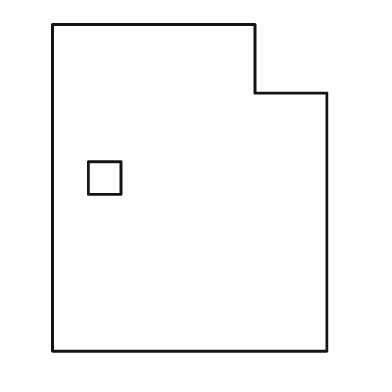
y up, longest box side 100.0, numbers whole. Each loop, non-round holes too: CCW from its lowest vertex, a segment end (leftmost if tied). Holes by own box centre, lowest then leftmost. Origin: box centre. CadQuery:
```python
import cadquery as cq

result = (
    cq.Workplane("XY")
    .moveTo(-42.0, -50.0)
    .lineTo(42.0, -50.0)
    .lineTo(42.0, 29.0)
    .lineTo(20.0, 29.0)
    .lineTo(20.0, 50.0)
    .lineTo(-42.0, 50.0)
    .close()
    .moveTo(-31.0, -2.0)
    .lineTo(-21.0, -2.0)
    .lineTo(-21.0, 8.0)
    .lineTo(-31.0, 8.0)
    .close()
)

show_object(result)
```